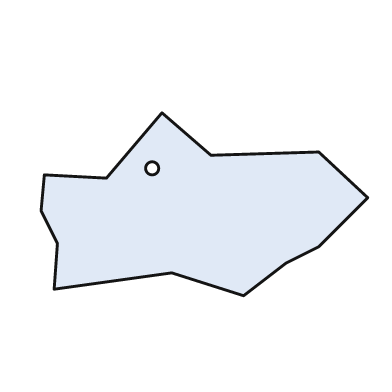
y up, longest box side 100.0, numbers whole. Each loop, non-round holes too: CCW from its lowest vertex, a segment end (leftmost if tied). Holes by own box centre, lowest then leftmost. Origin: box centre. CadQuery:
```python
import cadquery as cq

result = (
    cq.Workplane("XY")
    .moveTo(12.0, -28.0)
    .lineTo(25.0, -18.0)
    .lineTo(35.0, -13.0)
    .lineTo(50.0, 2.0)
    .lineTo(35.0, 16.0)
    .lineTo(2.0, 15.0)
    .lineTo(-13.0, 28.0)
    .lineTo(-30.0, 8.0)
    .lineTo(-49.0, 9.0)
    .lineTo(-50.0, -2.0)
    .lineTo(-45.0, -12.0)
    .lineTo(-46.0, -26.0)
    .lineTo(-10.0, -21.0)
    .close()
    .moveTo(-16.0, 11.0)
    .circle(2.0)
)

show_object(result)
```